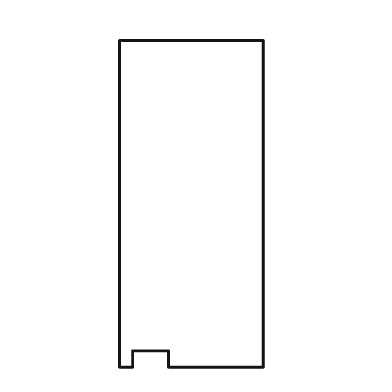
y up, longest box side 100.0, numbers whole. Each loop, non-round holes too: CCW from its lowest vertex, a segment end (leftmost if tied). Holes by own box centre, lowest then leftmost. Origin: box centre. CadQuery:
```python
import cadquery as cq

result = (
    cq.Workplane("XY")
    .moveTo(-22.0, -50.0)
    .lineTo(-18.0, -50.0)
    .lineTo(-18.0, -45.0)
    .lineTo(-7.0, -45.0)
    .lineTo(-7.0, -50.0)
    .lineTo(22.0, -50.0)
    .lineTo(22.0, 50.0)
    .lineTo(-22.0, 50.0)
    .close()
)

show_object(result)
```